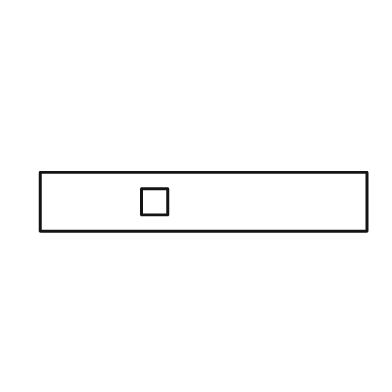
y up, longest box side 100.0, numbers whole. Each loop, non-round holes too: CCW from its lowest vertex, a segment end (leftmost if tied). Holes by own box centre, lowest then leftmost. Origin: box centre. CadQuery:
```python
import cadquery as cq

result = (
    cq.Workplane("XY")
    .moveTo(-50.0, -9.0)
    .lineTo(50.0, -9.0)
    .lineTo(50.0, 9.0)
    .lineTo(-50.0, 9.0)
    .close()
    .moveTo(-19.0, -4.0)
    .lineTo(-11.0, -4.0)
    .lineTo(-11.0, 4.0)
    .lineTo(-19.0, 4.0)
    .close()
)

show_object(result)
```